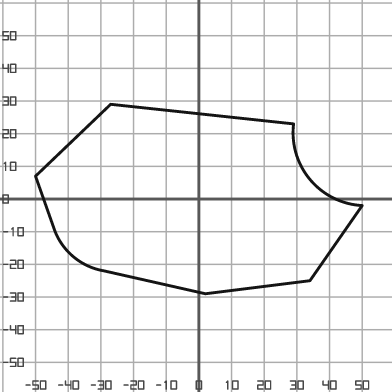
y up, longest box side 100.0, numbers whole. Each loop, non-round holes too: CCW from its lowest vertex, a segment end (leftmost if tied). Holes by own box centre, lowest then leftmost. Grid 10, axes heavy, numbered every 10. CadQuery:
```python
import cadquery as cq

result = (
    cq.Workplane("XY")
    .moveTo(2.0, -29.0)
    .lineTo(34.0, -25.0)
    .lineTo(50.0, -2.0)
    .threePointArc((34.0, 6.0), (29.0, 23.0))
    .lineTo(-27.0, 29.0)
    .lineTo(-50.0, 7.0)
    .lineTo(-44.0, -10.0)
    .threePointArc((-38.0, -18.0), (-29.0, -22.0))
    .close()
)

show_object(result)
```